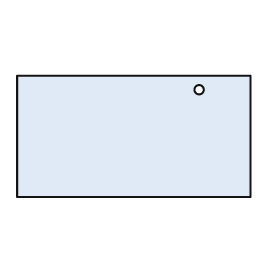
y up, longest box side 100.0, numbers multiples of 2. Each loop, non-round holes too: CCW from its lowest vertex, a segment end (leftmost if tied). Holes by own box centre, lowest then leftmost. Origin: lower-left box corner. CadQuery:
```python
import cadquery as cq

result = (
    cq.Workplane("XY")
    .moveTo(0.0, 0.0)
    .lineTo(100.0, 0.0)
    .lineTo(100.0, 52.0)
    .lineTo(0.0, 52.0)
    .close()
    .moveTo(78.0, 46.0)
    .circle(2.0)
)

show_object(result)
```